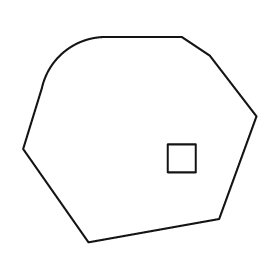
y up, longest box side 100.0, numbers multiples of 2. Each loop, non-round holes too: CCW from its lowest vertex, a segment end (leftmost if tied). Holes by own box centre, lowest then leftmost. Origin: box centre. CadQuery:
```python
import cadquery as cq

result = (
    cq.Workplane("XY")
    .moveTo(-22.0, -44.0)
    .lineTo(34.0, -34.0)
    .lineTo(50.0, 10.0)
    .lineTo(30.0, 36.0)
    .lineTo(18.0, 44.0)
    .lineTo(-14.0, 44.0)
    .threePointArc((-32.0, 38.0), (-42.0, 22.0))
    .lineTo(-50.0, -4.0)
    .close()
    .moveTo(12.0, -14.0)
    .lineTo(24.0, -14.0)
    .lineTo(24.0, -2.0)
    .lineTo(12.0, -2.0)
    .close()
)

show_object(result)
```